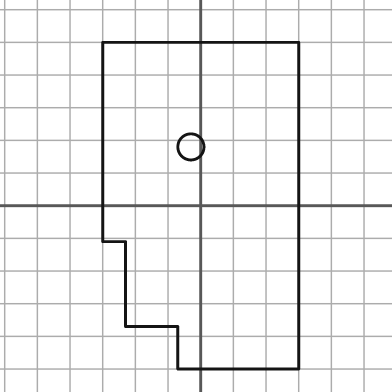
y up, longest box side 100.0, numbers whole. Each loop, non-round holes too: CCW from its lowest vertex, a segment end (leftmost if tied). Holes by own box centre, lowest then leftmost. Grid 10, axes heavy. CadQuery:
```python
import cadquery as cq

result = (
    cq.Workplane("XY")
    .moveTo(-7.0, -50.0)
    .lineTo(30.0, -50.0)
    .lineTo(30.0, 50.0)
    .lineTo(-30.0, 50.0)
    .lineTo(-30.0, -11.0)
    .lineTo(-23.0, -11.0)
    .lineTo(-23.0, -37.0)
    .lineTo(-7.0, -37.0)
    .close()
    .moveTo(-3.0, 18.0)
    .circle(4.0)
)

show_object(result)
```